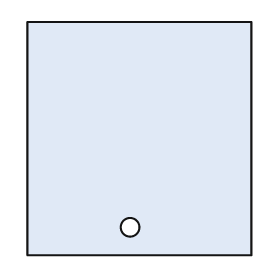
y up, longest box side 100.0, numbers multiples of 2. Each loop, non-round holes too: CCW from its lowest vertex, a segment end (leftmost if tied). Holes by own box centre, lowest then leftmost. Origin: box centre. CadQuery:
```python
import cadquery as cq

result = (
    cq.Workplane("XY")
    .moveTo(-48.0, -50.0)
    .lineTo(48.0, -50.0)
    .lineTo(48.0, 50.0)
    .lineTo(-48.0, 50.0)
    .close()
    .moveTo(-4.0, -38.0)
    .circle(4.0)
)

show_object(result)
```